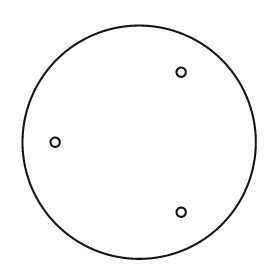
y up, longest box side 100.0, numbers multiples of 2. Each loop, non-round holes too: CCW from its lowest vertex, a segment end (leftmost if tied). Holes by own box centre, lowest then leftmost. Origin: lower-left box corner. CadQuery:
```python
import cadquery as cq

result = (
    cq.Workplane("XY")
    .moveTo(50.0, 50.0)
    .circle(50.0)
    .moveTo(68.0, 20.0)
    .circle(2.0)
    .moveTo(14.0, 50.0)
    .circle(2.0)
    .moveTo(68.0, 80.0)
    .circle(2.0)
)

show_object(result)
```